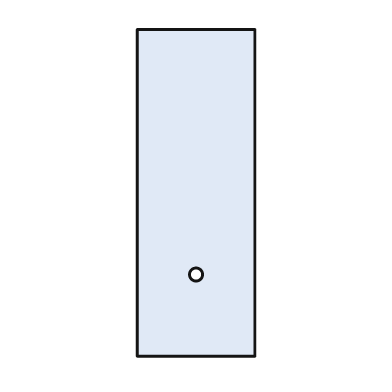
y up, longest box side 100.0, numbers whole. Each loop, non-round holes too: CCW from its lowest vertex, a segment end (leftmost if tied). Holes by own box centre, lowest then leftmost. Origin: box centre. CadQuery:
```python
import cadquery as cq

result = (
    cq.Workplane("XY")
    .moveTo(-18.0, -50.0)
    .lineTo(18.0, -50.0)
    .lineTo(18.0, 50.0)
    .lineTo(-18.0, 50.0)
    .close()
    .moveTo(0.0, -25.0)
    .circle(2.0)
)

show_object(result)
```